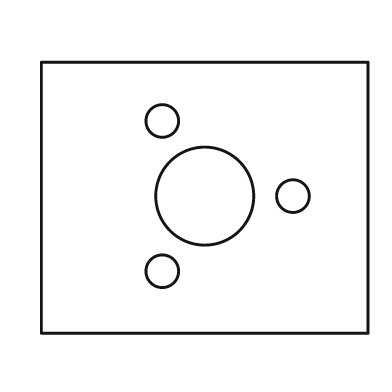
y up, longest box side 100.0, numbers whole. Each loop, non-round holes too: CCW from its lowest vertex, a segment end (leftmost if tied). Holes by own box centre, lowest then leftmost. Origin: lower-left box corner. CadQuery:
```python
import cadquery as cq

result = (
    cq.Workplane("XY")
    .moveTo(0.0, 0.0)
    .lineTo(100.0, 0.0)
    .lineTo(100.0, 83.0)
    .lineTo(0.0, 83.0)
    .close()
    .moveTo(37.0, 19.0)
    .circle(5.0)
    .moveTo(50.0, 42.0)
    .circle(15.0)
    .moveTo(77.0, 42.0)
    .circle(5.0)
    .moveTo(37.0, 65.0)
    .circle(5.0)
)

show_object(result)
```